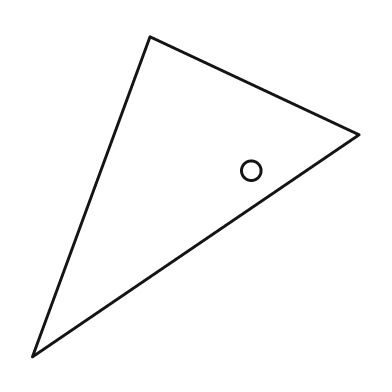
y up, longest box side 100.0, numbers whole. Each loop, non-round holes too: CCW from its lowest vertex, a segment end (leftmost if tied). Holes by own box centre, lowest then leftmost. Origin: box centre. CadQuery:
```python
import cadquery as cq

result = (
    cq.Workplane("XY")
    .moveTo(-50.0, -49.0)
    .lineTo(50.0, 19.0)
    .lineTo(-14.0, 49.0)
    .close()
    .moveTo(17.0, 8.0)
    .circle(3.0)
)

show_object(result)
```